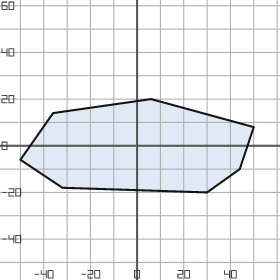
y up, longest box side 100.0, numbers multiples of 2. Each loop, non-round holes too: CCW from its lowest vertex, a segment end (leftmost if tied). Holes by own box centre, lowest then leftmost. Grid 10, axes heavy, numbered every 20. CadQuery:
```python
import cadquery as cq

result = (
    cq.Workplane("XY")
    .moveTo(30.0, -20.0)
    .lineTo(44.0, -10.0)
    .lineTo(50.0, 8.0)
    .lineTo(6.0, 20.0)
    .lineTo(-36.0, 14.0)
    .lineTo(-50.0, -6.0)
    .lineTo(-32.0, -18.0)
    .close()
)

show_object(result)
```